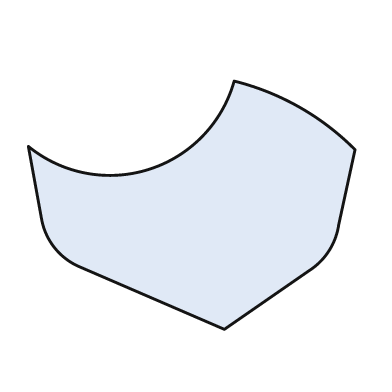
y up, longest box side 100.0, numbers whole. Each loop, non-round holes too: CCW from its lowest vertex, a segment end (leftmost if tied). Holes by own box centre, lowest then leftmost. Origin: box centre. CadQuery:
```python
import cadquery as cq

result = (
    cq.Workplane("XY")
    .moveTo(10.0, -38.0)
    .lineTo(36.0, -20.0)
    .threePointArc((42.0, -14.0), (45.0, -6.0))
    .lineTo(50.0, 17.0)
    .threePointArc((33.0, 30.0), (13.0, 38.0))
    .threePointArc((-13.0, 11.0), (-50.0, 18.0))
    .lineTo(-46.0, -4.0)
    .threePointArc((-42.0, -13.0), (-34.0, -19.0))
    .close()
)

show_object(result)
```